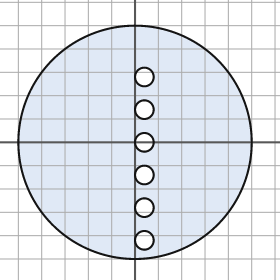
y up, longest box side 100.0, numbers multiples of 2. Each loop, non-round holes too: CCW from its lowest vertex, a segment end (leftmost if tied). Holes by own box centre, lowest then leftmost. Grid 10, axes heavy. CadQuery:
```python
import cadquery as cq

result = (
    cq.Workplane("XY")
    .moveTo(0.0, 0.0)
    .circle(50.0)
    .moveTo(4.0, -42.0)
    .circle(4.0)
    .moveTo(4.0, -28.0)
    .circle(4.0)
    .moveTo(4.0, -14.0)
    .circle(4.0)
    .moveTo(4.0, 0.0)
    .circle(4.0)
    .moveTo(4.0, 14.0)
    .circle(4.0)
    .moveTo(4.0, 28.0)
    .circle(4.0)
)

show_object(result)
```